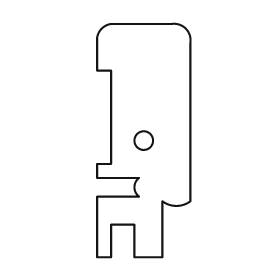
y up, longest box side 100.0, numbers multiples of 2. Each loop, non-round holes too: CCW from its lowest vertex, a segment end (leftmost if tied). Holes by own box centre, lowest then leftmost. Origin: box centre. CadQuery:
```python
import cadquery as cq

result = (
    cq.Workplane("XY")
    .moveTo(-20.0, -50.0)
    .lineTo(-14.0, -50.0)
    .lineTo(-14.0, -36.0)
    .lineTo(-4.0, -36.0)
    .lineTo(-4.0, -50.0)
    .lineTo(8.0, -50.0)
    .lineTo(8.0, -26.0)
    .threePointArc((14.0, -28.0), (20.0, -26.0))
    .lineTo(20.0, 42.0)
    .threePointArc((18.0, 48.0), (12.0, 50.0))
    .lineTo(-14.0, 50.0)
    .threePointArc((-18.0, 48.0), (-20.0, 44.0))
    .lineTo(-20.0, 30.0)
    .lineTo(-14.0, 30.0)
    .lineTo(-14.0, -10.0)
    .lineTo(-20.0, -10.0)
    .lineTo(-20.0, -16.0)
    .lineTo(-2.0, -16.0)
    .threePointArc((-4.0, -20.0), (-2.0, -24.0))
    .lineTo(-20.0, -24.0)
    .close()
    .moveTo(0.0, 0.0)
    .circle(4.0)
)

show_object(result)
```